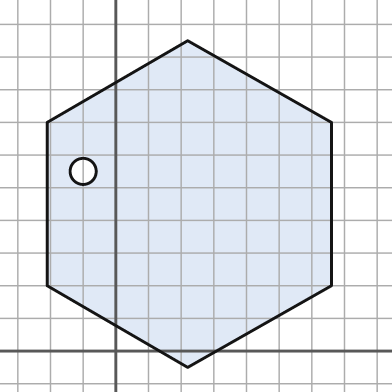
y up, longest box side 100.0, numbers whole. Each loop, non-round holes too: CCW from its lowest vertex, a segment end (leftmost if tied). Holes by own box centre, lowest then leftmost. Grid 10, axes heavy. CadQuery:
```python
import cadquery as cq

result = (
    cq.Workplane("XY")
    .moveTo(22.0, -5.0)
    .lineTo(66.0, 20.0)
    .lineTo(66.0, 70.0)
    .lineTo(22.0, 95.0)
    .lineTo(-21.0, 70.0)
    .lineTo(-21.0, 20.0)
    .close()
    .moveTo(-10.0, 55.0)
    .circle(4.0)
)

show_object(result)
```